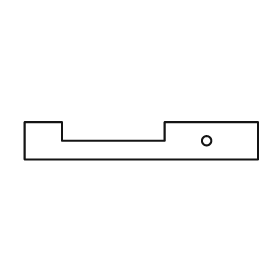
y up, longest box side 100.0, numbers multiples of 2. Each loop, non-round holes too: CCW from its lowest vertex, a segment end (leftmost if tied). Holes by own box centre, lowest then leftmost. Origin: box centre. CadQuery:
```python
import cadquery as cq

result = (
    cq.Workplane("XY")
    .moveTo(-50.0, -8.0)
    .lineTo(50.0, -8.0)
    .lineTo(50.0, 8.0)
    .lineTo(10.0, 8.0)
    .lineTo(10.0, 0.0)
    .lineTo(-34.0, 0.0)
    .lineTo(-34.0, 8.0)
    .lineTo(-50.0, 8.0)
    .close()
    .moveTo(28.0, 0.0)
    .circle(2.0)
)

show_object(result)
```